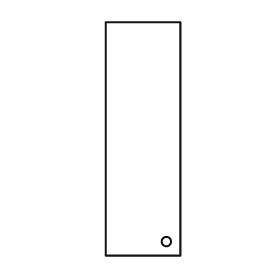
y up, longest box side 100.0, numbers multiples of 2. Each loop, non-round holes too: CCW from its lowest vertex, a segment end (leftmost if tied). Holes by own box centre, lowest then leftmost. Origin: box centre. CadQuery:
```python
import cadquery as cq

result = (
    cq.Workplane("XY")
    .moveTo(-16.0, -50.0)
    .lineTo(16.0, -50.0)
    .lineTo(16.0, 50.0)
    .lineTo(-16.0, 50.0)
    .close()
    .moveTo(10.0, -44.0)
    .circle(2.0)
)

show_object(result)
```